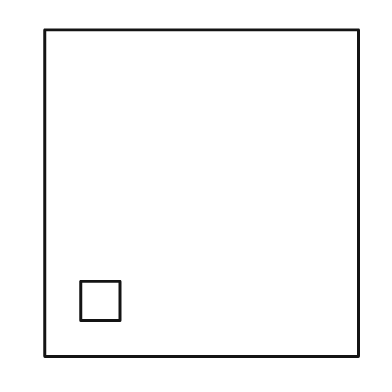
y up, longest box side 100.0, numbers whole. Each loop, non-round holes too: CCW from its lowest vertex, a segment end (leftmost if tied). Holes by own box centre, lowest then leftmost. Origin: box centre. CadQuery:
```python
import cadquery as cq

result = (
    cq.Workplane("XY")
    .moveTo(-48.0, -50.0)
    .lineTo(48.0, -50.0)
    .lineTo(48.0, 50.0)
    .lineTo(-48.0, 50.0)
    .close()
    .moveTo(-37.0, -39.0)
    .lineTo(-25.0, -39.0)
    .lineTo(-25.0, -27.0)
    .lineTo(-37.0, -27.0)
    .close()
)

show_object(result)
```